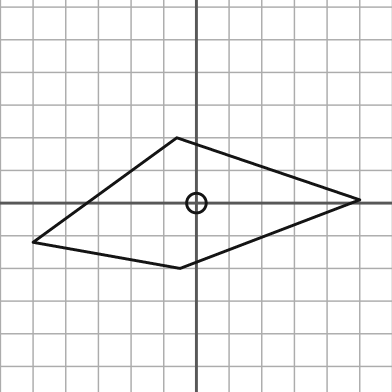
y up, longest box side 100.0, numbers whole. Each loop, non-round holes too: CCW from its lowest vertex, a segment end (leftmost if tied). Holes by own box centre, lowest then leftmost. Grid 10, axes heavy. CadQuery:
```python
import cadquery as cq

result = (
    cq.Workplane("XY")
    .moveTo(-5.0, -20.0)
    .lineTo(50.0, 1.0)
    .lineTo(-6.0, 20.0)
    .lineTo(-50.0, -12.0)
    .close()
    .moveTo(0.0, 0.0)
    .circle(3.0)
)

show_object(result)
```